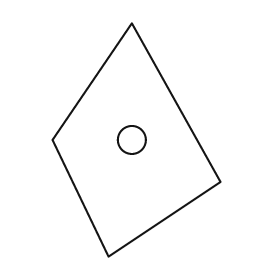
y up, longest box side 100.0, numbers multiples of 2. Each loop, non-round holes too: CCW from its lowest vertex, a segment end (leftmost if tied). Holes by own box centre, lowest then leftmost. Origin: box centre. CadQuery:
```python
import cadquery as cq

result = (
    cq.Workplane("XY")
    .moveTo(-12.0, -50.0)
    .lineTo(36.0, -18.0)
    .lineTo(-2.0, 50.0)
    .lineTo(-36.0, 0.0)
    .close()
    .moveTo(-2.0, 0.0)
    .circle(6.0)
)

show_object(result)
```